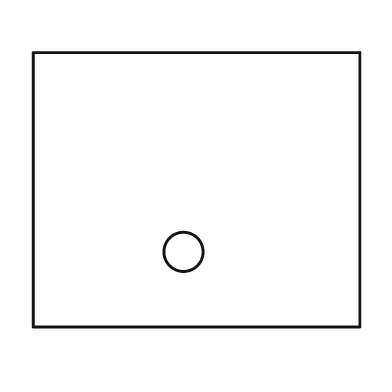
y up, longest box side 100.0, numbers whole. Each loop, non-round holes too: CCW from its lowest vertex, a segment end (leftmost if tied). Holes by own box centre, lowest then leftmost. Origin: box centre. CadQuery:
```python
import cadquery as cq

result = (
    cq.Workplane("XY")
    .moveTo(-50.0, -42.0)
    .lineTo(50.0, -42.0)
    .lineTo(50.0, 42.0)
    .lineTo(-50.0, 42.0)
    .close()
    .moveTo(-4.0, -19.0)
    .circle(6.0)
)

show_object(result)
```